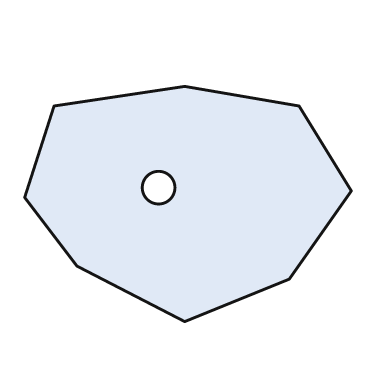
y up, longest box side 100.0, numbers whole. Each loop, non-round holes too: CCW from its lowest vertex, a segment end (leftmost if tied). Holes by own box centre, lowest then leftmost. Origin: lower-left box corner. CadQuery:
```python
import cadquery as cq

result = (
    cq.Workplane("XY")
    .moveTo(49.0, 0.0)
    .lineTo(81.0, 13.0)
    .lineTo(100.0, 40.0)
    .lineTo(84.0, 66.0)
    .lineTo(49.0, 72.0)
    .lineTo(9.0, 66.0)
    .lineTo(0.0, 38.0)
    .lineTo(16.0, 17.0)
    .close()
    .moveTo(41.0, 41.0)
    .circle(5.0)
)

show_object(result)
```